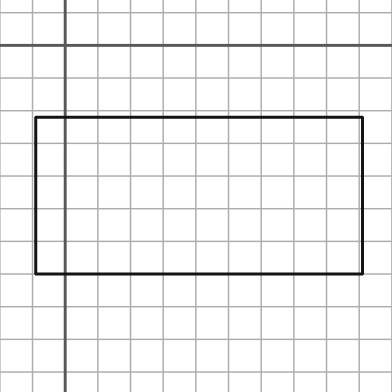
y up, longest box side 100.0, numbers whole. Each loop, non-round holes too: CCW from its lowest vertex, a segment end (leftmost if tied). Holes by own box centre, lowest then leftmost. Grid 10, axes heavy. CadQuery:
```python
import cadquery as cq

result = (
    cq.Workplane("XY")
    .moveTo(-9.0, -70.0)
    .lineTo(91.0, -70.0)
    .lineTo(91.0, -22.0)
    .lineTo(-9.0, -22.0)
    .close()
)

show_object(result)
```